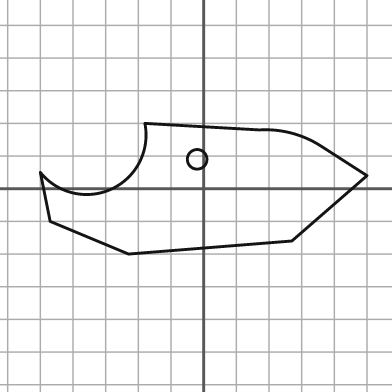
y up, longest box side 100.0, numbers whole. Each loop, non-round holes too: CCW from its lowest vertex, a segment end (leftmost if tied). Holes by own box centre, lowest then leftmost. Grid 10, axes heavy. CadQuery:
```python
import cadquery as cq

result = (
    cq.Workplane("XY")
    .moveTo(-23.0, -20.0)
    .lineTo(27.0, -16.0)
    .lineTo(50.0, 4.0)
    .lineTo(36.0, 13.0)
    .threePointArc((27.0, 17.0), (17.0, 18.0))
    .lineTo(-18.0, 20.0)
    .threePointArc((-28.0, 0.0), (-50.0, 5.0))
    .lineTo(-47.0, -10.0)
    .close()
    .moveTo(-2.0, 9.0)
    .circle(3.0)
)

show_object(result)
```